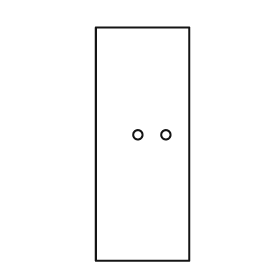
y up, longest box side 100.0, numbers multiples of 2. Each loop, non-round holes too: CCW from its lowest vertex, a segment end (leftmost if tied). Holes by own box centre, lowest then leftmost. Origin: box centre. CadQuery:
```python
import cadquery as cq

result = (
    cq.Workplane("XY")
    .moveTo(-20.0, -50.0)
    .lineTo(20.0, -50.0)
    .lineTo(20.0, 50.0)
    .lineTo(-20.0, 50.0)
    .close()
    .moveTo(-2.0, 4.0)
    .circle(2.0)
    .moveTo(10.0, 4.0)
    .circle(2.0)
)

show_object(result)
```